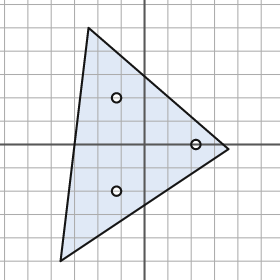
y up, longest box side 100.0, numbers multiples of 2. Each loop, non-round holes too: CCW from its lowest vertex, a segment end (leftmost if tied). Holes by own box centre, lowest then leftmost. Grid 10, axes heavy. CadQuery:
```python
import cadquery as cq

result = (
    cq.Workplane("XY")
    .moveTo(-36.0, -50.0)
    .lineTo(36.0, -2.0)
    .lineTo(-24.0, 50.0)
    .close()
    .moveTo(-12.0, -20.0)
    .circle(2.0)
    .moveTo(22.0, 0.0)
    .circle(2.0)
    .moveTo(-12.0, 20.0)
    .circle(2.0)
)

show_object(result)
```